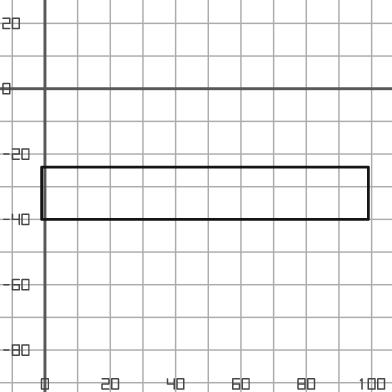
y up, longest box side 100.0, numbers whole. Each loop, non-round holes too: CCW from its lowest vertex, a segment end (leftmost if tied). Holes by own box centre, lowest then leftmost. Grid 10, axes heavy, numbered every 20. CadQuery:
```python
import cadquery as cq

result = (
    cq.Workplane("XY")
    .moveTo(-1.0, -40.0)
    .lineTo(99.0, -40.0)
    .lineTo(99.0, -24.0)
    .lineTo(-1.0, -24.0)
    .close()
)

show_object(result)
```